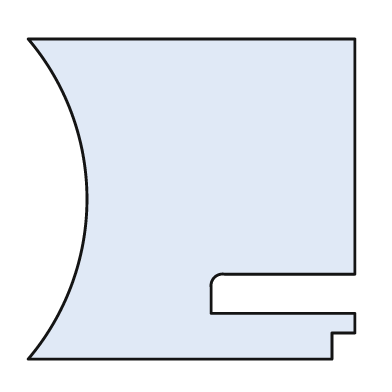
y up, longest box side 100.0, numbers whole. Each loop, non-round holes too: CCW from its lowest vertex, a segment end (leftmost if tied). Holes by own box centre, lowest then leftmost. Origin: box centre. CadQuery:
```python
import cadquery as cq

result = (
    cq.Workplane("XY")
    .moveTo(-50.0, -49.0)
    .lineTo(43.0, -49.0)
    .lineTo(43.0, -41.0)
    .lineTo(50.0, -41.0)
    .lineTo(50.0, -35.0)
    .lineTo(6.0, -35.0)
    .lineTo(6.0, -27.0)
    .threePointArc((7.0, -24.0), (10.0, -23.0))
    .lineTo(50.0, -23.0)
    .lineTo(50.0, 49.0)
    .lineTo(-50.0, 49.0)
    .threePointArc((-32.0, 0.0), (-50.0, -49.0))
    .close()
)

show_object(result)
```